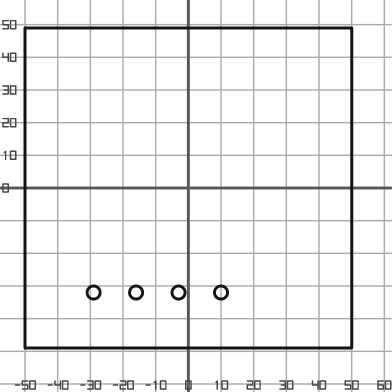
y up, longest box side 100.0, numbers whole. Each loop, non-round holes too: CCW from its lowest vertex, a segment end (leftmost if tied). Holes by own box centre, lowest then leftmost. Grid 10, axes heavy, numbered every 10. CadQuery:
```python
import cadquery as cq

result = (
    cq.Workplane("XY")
    .moveTo(-50.0, -49.0)
    .lineTo(50.0, -49.0)
    .lineTo(50.0, 49.0)
    .lineTo(-50.0, 49.0)
    .close()
    .moveTo(-29.0, -32.0)
    .circle(2.0)
    .moveTo(-16.0, -32.0)
    .circle(2.0)
    .moveTo(-3.0, -32.0)
    .circle(2.0)
    .moveTo(10.0, -32.0)
    .circle(2.0)
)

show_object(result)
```